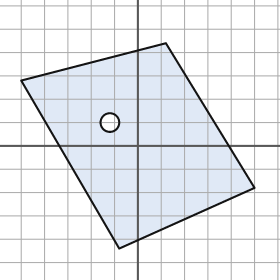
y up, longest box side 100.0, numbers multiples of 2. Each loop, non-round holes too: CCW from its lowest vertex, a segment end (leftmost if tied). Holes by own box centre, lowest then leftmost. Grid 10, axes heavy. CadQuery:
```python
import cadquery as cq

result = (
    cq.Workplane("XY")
    .moveTo(-8.0, -44.0)
    .lineTo(50.0, -18.0)
    .lineTo(12.0, 44.0)
    .lineTo(-50.0, 28.0)
    .close()
    .moveTo(-12.0, 10.0)
    .circle(4.0)
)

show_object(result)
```